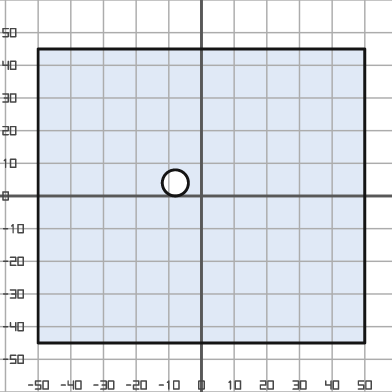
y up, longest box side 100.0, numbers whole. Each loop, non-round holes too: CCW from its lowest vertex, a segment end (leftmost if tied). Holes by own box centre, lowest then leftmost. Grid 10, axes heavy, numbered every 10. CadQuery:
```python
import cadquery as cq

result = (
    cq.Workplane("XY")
    .moveTo(-50.0, -45.0)
    .lineTo(50.0, -45.0)
    .lineTo(50.0, 45.0)
    .lineTo(-50.0, 45.0)
    .close()
    .moveTo(-8.0, 4.0)
    .circle(4.0)
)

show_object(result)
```